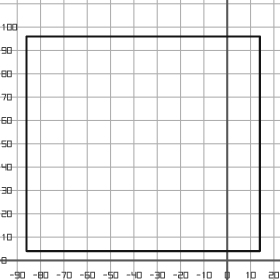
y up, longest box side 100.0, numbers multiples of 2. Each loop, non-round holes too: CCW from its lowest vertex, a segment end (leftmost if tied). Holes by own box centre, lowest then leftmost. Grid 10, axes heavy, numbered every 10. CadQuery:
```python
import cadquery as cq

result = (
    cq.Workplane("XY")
    .moveTo(-86.0, 4.0)
    .lineTo(14.0, 4.0)
    .lineTo(14.0, 96.0)
    .lineTo(-86.0, 96.0)
    .close()
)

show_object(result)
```